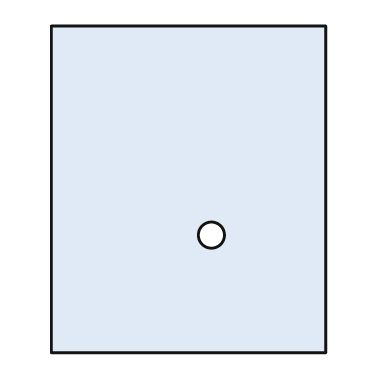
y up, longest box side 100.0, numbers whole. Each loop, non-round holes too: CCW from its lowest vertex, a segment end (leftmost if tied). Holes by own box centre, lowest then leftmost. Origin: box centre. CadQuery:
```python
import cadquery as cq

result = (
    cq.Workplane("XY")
    .moveTo(-42.0, -50.0)
    .lineTo(42.0, -50.0)
    .lineTo(42.0, 50.0)
    .lineTo(-42.0, 50.0)
    .close()
    .moveTo(7.0, -14.0)
    .circle(4.0)
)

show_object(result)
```